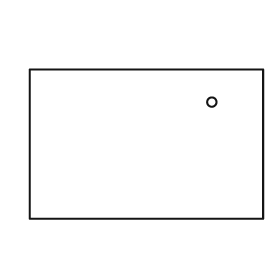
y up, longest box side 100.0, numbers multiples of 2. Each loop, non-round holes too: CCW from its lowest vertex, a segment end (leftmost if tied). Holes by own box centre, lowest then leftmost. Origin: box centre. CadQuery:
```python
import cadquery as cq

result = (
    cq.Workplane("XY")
    .moveTo(-50.0, -32.0)
    .lineTo(50.0, -32.0)
    .lineTo(50.0, 32.0)
    .lineTo(-50.0, 32.0)
    .close()
    .moveTo(28.0, 18.0)
    .circle(2.0)
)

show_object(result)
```